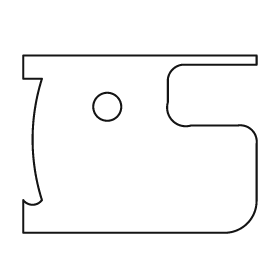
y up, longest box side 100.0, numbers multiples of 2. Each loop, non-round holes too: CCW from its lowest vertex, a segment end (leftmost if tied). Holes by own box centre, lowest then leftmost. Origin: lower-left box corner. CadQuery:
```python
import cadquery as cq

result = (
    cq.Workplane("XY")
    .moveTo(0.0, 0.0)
    .lineTo(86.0, 0.0)
    .threePointArc((96.0, 4.0), (100.0, 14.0))
    .lineTo(100.0, 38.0)
    .threePointArc((98.0, 44.0), (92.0, 46.0))
    .lineTo(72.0, 46.0)
    .threePointArc((64.0, 48.0), (62.0, 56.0))
    .lineTo(62.0, 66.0)
    .threePointArc((64.0, 70.0), (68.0, 72.0))
    .lineTo(100.0, 72.0)
    .lineTo(100.0, 76.0)
    .lineTo(0.0, 76.0)
    .lineTo(0.0, 66.0)
    .lineTo(8.0, 66.0)
    .threePointArc((4.0, 40.0), (8.0, 14.0))
    .threePointArc((4.0, 12.0), (0.0, 14.0))
    .close()
    .moveTo(36.0, 54.0)
    .circle(6.0)
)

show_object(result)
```